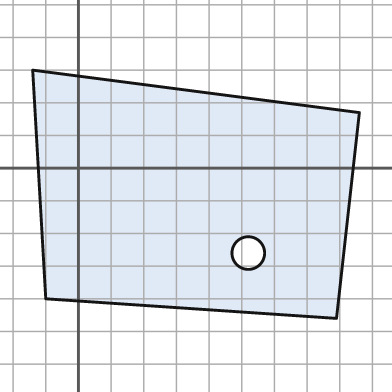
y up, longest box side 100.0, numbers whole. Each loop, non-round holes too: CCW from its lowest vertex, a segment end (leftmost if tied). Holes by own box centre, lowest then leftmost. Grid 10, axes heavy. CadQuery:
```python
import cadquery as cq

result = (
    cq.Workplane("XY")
    .moveTo(79.0, -46.0)
    .lineTo(86.0, 17.0)
    .lineTo(-14.0, 30.0)
    .lineTo(-10.0, -40.0)
    .close()
    .moveTo(52.0, -26.0)
    .circle(5.0)
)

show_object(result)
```